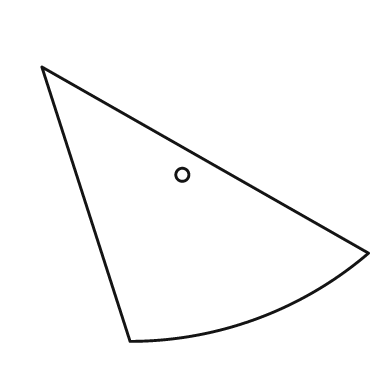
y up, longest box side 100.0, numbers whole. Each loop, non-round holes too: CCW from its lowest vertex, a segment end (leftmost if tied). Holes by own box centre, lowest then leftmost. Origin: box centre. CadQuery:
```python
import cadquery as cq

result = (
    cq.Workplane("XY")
    .moveTo(-23.0, -42.0)
    .threePointArc((16.0, -35.0), (50.0, -15.0))
    .lineTo(-50.0, 42.0)
    .close()
    .moveTo(-7.0, 9.0)
    .circle(2.0)
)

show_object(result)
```